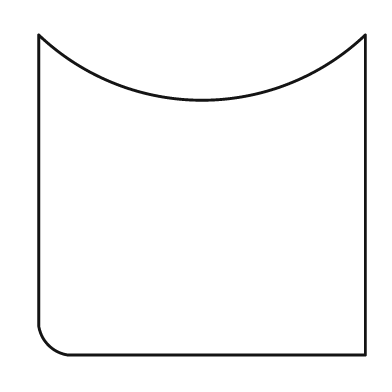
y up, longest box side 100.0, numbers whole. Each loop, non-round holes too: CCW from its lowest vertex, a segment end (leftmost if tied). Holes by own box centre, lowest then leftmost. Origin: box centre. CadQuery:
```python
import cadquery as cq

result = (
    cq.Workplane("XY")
    .moveTo(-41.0, -49.0)
    .lineTo(50.0, -49.0)
    .lineTo(50.0, 49.0)
    .threePointArc((0.0, 29.0), (-50.0, 49.0))
    .lineTo(-50.0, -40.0)
    .threePointArc((-47.0, -46.0), (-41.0, -49.0))
    .close()
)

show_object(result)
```